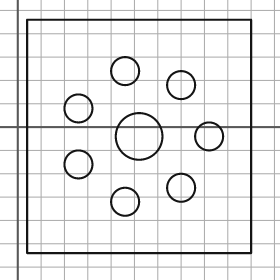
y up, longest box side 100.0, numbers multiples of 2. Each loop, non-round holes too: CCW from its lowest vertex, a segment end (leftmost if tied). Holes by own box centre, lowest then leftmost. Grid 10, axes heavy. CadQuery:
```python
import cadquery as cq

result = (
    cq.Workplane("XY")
    .moveTo(4.0, -54.0)
    .lineTo(100.0, -54.0)
    .lineTo(100.0, 46.0)
    .lineTo(4.0, 46.0)
    .close()
    .moveTo(46.0, -32.0)
    .circle(6.0)
    .moveTo(70.0, -26.0)
    .circle(6.0)
    .moveTo(26.0, -16.0)
    .circle(6.0)
    .moveTo(52.0, -4.0)
    .circle(10.0)
    .moveTo(82.0, -4.0)
    .circle(6.0)
    .moveTo(26.0, 8.0)
    .circle(6.0)
    .moveTo(70.0, 18.0)
    .circle(6.0)
    .moveTo(46.0, 24.0)
    .circle(6.0)
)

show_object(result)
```